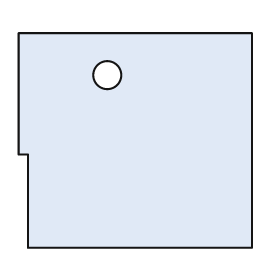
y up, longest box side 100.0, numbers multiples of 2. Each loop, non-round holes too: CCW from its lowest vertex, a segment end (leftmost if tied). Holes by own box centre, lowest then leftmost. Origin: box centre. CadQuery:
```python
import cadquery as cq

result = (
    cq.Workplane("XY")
    .moveTo(-46.0, -46.0)
    .lineTo(50.0, -46.0)
    .lineTo(50.0, 46.0)
    .lineTo(-50.0, 46.0)
    .lineTo(-50.0, -6.0)
    .lineTo(-46.0, -6.0)
    .close()
    .moveTo(-12.0, 28.0)
    .circle(6.0)
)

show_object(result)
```